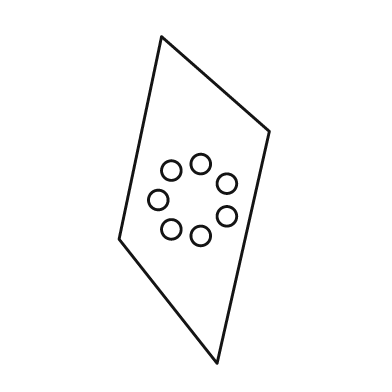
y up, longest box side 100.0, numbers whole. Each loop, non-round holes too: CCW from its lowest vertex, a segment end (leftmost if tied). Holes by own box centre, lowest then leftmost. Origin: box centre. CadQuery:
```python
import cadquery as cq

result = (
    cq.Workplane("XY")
    .moveTo(7.0, -50.0)
    .lineTo(23.0, 21.0)
    .lineTo(-10.0, 50.0)
    .lineTo(-23.0, -12.0)
    .close()
    .moveTo(2.0, -11.0)
    .circle(3.0)
    .moveTo(-7.0, -9.0)
    .circle(3.0)
    .moveTo(10.0, -5.0)
    .circle(3.0)
    .moveTo(-11.0, 0.0)
    .circle(3.0)
    .moveTo(10.0, 5.0)
    .circle(3.0)
    .moveTo(-7.0, 9.0)
    .circle(3.0)
    .moveTo(2.0, 11.0)
    .circle(3.0)
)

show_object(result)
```